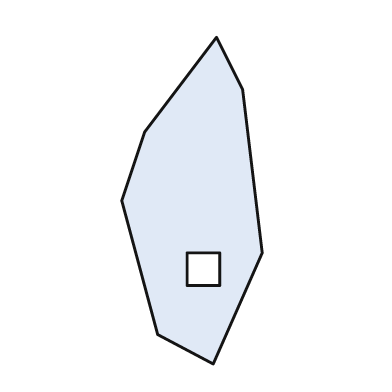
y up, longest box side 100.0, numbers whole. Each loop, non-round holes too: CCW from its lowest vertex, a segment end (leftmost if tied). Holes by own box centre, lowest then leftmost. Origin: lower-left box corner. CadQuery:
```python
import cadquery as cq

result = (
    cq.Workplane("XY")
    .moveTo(28.0, 0.0)
    .lineTo(43.0, 34.0)
    .lineTo(37.0, 84.0)
    .lineTo(29.0, 100.0)
    .lineTo(7.0, 71.0)
    .lineTo(0.0, 50.0)
    .lineTo(11.0, 9.0)
    .close()
    .moveTo(20.0, 24.0)
    .lineTo(30.0, 24.0)
    .lineTo(30.0, 34.0)
    .lineTo(20.0, 34.0)
    .close()
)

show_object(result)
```